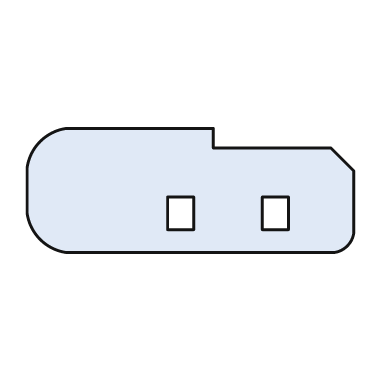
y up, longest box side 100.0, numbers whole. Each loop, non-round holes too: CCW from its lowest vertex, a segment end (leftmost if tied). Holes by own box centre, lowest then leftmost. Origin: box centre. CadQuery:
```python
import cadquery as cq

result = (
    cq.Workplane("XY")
    .moveTo(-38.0, -19.0)
    .lineTo(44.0, -19.0)
    .threePointArc((48.0, -17.0), (50.0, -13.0))
    .lineTo(50.0, 6.0)
    .lineTo(43.0, 13.0)
    .lineTo(7.0, 13.0)
    .lineTo(7.0, 19.0)
    .lineTo(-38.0, 19.0)
    .threePointArc((-46.0, 15.0), (-50.0, 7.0))
    .lineTo(-50.0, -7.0)
    .threePointArc((-46.0, -15.0), (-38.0, -19.0))
    .close()
    .moveTo(-7.0, -12.0)
    .lineTo(1.0, -12.0)
    .lineTo(1.0, -2.0)
    .lineTo(-7.0, -2.0)
    .close()
    .moveTo(22.0, -12.0)
    .lineTo(30.0, -12.0)
    .lineTo(30.0, -2.0)
    .lineTo(22.0, -2.0)
    .close()
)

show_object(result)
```